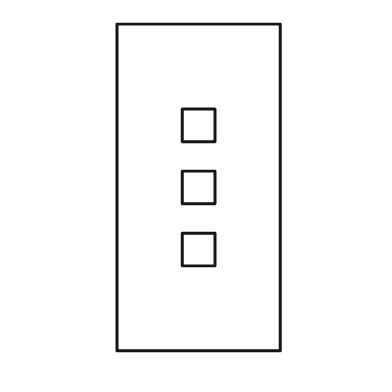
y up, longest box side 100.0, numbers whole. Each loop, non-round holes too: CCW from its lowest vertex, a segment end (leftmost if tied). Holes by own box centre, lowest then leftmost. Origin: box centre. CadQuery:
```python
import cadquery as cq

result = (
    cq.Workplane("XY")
    .moveTo(-25.0, -50.0)
    .lineTo(25.0, -50.0)
    .lineTo(25.0, 50.0)
    .lineTo(-25.0, 50.0)
    .close()
    .moveTo(-5.0, -24.0)
    .lineTo(5.0, -24.0)
    .lineTo(5.0, -14.0)
    .lineTo(-5.0, -14.0)
    .close()
    .moveTo(-5.0, -5.0)
    .lineTo(5.0, -5.0)
    .lineTo(5.0, 5.0)
    .lineTo(-5.0, 5.0)
    .close()
    .moveTo(-5.0, 14.0)
    .lineTo(5.0, 14.0)
    .lineTo(5.0, 24.0)
    .lineTo(-5.0, 24.0)
    .close()
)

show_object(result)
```